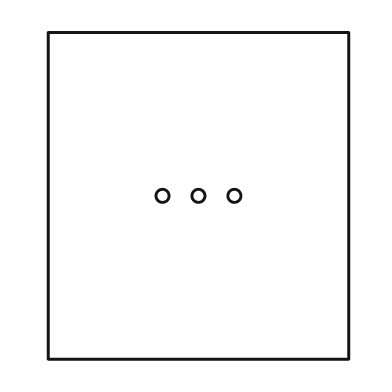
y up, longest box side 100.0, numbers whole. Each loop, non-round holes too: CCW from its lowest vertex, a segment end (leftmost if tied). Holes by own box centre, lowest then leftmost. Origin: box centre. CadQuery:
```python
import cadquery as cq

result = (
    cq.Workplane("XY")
    .moveTo(-46.0, -50.0)
    .lineTo(46.0, -50.0)
    .lineTo(46.0, 50.0)
    .lineTo(-46.0, 50.0)
    .close()
    .moveTo(-11.0, 0.0)
    .circle(2.0)
    .moveTo(0.0, 0.0)
    .circle(2.0)
    .moveTo(11.0, 0.0)
    .circle(2.0)
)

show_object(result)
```